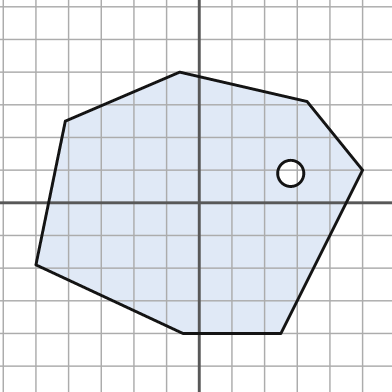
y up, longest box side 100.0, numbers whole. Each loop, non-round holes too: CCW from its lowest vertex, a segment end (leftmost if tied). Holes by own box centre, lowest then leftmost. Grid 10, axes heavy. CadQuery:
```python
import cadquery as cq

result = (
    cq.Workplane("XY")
    .moveTo(-5.0, -40.0)
    .lineTo(25.0, -40.0)
    .lineTo(50.0, 10.0)
    .lineTo(33.0, 31.0)
    .lineTo(-6.0, 40.0)
    .lineTo(-41.0, 25.0)
    .lineTo(-50.0, -19.0)
    .close()
    .moveTo(28.0, 9.0)
    .circle(4.0)
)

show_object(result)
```